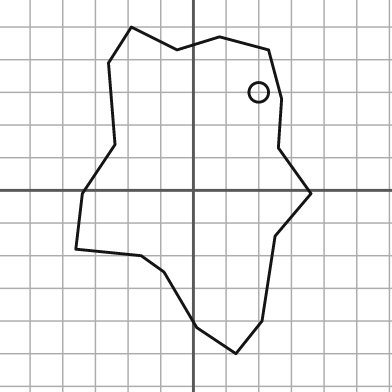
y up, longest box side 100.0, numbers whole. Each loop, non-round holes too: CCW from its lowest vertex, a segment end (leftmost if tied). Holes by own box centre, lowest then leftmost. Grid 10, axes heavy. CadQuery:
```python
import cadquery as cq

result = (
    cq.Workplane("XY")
    .moveTo(13.0, -50.0)
    .lineTo(21.0, -40.0)
    .lineTo(25.0, -14.0)
    .lineTo(36.0, -1.0)
    .lineTo(26.0, 13.0)
    .lineTo(27.0, 28.0)
    .lineTo(23.0, 43.0)
    .lineTo(8.0, 47.0)
    .lineTo(-5.0, 43.0)
    .lineTo(-19.0, 50.0)
    .lineTo(-26.0, 39.0)
    .lineTo(-24.0, 14.0)
    .lineTo(-34.0, -1.0)
    .lineTo(-36.0, -18.0)
    .lineTo(-16.0, -20.0)
    .lineTo(-9.0, -25.0)
    .lineTo(1.0, -42.0)
    .close()
    .moveTo(20.0, 30.0)
    .circle(3.0)
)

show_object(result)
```